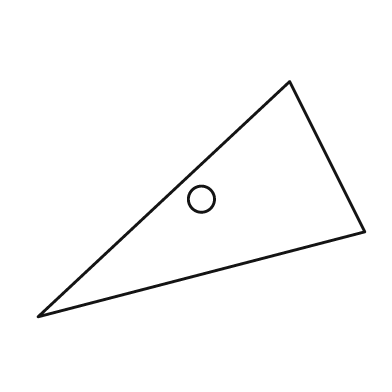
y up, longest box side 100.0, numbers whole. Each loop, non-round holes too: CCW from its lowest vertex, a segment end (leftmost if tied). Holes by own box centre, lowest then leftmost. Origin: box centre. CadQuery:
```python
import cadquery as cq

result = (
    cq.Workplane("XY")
    .moveTo(-50.0, -36.0)
    .lineTo(50.0, -10.0)
    .lineTo(27.0, 36.0)
    .close()
    .moveTo(0.0, 0.0)
    .circle(4.0)
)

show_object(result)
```